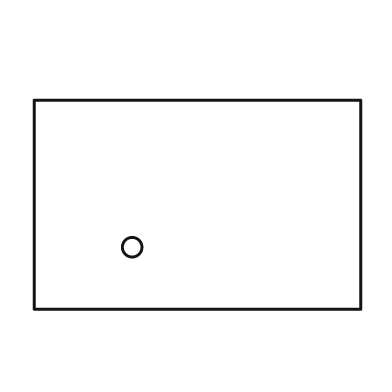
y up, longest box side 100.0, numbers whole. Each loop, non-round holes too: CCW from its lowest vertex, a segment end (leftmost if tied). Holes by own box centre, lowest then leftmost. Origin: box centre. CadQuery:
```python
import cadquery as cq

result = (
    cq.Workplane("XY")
    .moveTo(-50.0, -32.0)
    .lineTo(50.0, -32.0)
    .lineTo(50.0, 32.0)
    .lineTo(-50.0, 32.0)
    .close()
    .moveTo(-20.0, -13.0)
    .circle(3.0)
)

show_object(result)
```